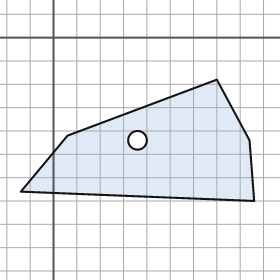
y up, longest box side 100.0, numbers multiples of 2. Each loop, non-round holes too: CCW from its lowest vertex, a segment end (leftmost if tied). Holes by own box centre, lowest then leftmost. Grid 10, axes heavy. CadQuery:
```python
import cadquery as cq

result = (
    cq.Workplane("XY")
    .moveTo(86.0, -70.0)
    .lineTo(84.0, -44.0)
    .lineTo(70.0, -18.0)
    .lineTo(6.0, -42.0)
    .lineTo(-14.0, -66.0)
    .close()
    .moveTo(36.0, -44.0)
    .circle(4.0)
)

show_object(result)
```